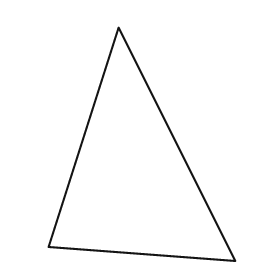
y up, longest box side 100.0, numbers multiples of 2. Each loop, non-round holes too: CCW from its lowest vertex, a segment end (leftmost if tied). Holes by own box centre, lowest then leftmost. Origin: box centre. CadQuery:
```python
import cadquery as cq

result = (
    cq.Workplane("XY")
    .moveTo(40.0, -50.0)
    .lineTo(-10.0, 50.0)
    .lineTo(-40.0, -44.0)
    .close()
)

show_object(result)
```